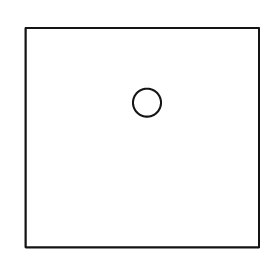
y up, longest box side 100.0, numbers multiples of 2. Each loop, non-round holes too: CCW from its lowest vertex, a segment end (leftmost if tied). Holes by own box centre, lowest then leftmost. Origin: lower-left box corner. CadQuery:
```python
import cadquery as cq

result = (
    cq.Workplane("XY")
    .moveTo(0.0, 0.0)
    .lineTo(100.0, 0.0)
    .lineTo(100.0, 94.0)
    .lineTo(0.0, 94.0)
    .close()
    .moveTo(52.0, 62.0)
    .circle(6.0)
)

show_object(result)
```